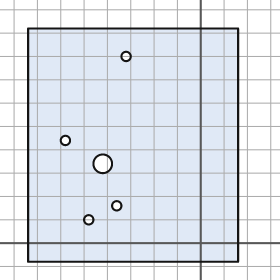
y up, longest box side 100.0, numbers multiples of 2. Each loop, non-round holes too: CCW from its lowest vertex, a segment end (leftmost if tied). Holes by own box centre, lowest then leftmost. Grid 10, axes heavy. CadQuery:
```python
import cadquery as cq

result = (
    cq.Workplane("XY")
    .moveTo(-74.0, -8.0)
    .lineTo(16.0, -8.0)
    .lineTo(16.0, 92.0)
    .lineTo(-74.0, 92.0)
    .close()
    .moveTo(-48.0, 10.0)
    .circle(2.0)
    .moveTo(-36.0, 16.0)
    .circle(2.0)
    .moveTo(-42.0, 34.0)
    .circle(4.0)
    .moveTo(-58.0, 44.0)
    .circle(2.0)
    .moveTo(-32.0, 80.0)
    .circle(2.0)
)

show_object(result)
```